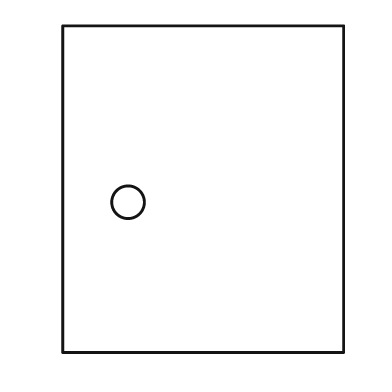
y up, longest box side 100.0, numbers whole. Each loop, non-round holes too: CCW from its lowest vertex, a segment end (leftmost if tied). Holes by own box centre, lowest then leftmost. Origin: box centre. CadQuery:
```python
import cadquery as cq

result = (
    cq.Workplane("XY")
    .moveTo(-43.0, -50.0)
    .lineTo(43.0, -50.0)
    .lineTo(43.0, 50.0)
    .lineTo(-43.0, 50.0)
    .close()
    .moveTo(-23.0, -4.0)
    .circle(5.0)
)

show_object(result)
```